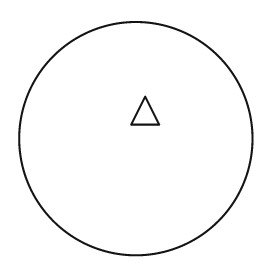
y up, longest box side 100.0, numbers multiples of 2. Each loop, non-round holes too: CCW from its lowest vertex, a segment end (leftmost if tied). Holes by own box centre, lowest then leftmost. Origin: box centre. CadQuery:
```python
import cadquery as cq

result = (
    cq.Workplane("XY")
    .moveTo(0.0, 0.0)
    .circle(50.0)
    .moveTo(-2.0, 6.0)
    .lineTo(10.0, 6.0)
    .lineTo(4.0, 18.0)
    .close()
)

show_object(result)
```